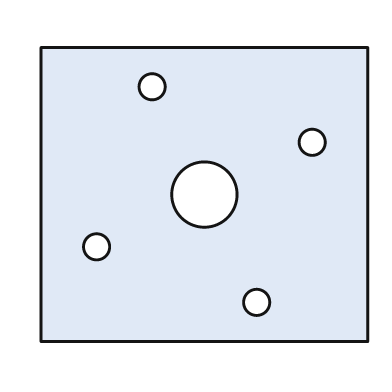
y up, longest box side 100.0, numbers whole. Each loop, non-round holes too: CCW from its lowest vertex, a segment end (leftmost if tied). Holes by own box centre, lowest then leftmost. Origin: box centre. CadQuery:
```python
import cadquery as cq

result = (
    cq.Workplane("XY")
    .moveTo(-50.0, -45.0)
    .lineTo(50.0, -45.0)
    .lineTo(50.0, 45.0)
    .lineTo(-50.0, 45.0)
    .close()
    .moveTo(16.0, -33.0)
    .circle(4.0)
    .moveTo(-33.0, -16.0)
    .circle(4.0)
    .moveTo(0.0, 0.0)
    .circle(10.0)
    .moveTo(33.0, 16.0)
    .circle(4.0)
    .moveTo(-16.0, 33.0)
    .circle(4.0)
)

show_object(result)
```